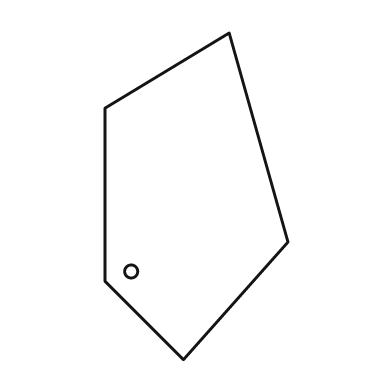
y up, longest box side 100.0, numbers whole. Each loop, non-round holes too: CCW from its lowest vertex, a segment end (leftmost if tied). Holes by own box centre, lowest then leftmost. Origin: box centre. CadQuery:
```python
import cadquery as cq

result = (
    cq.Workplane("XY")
    .moveTo(-4.0, -50.0)
    .lineTo(28.0, -14.0)
    .lineTo(10.0, 50.0)
    .lineTo(-28.0, 27.0)
    .lineTo(-28.0, -26.0)
    .close()
    .moveTo(-20.0, -23.0)
    .circle(2.0)
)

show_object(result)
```